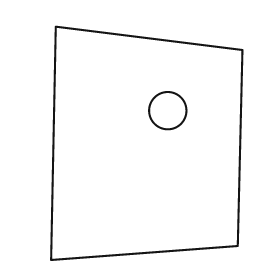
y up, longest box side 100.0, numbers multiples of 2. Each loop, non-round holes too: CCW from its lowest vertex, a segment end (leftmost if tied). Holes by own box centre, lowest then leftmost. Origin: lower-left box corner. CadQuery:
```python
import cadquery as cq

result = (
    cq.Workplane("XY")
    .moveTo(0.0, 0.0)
    .lineTo(80.0, 6.0)
    .lineTo(82.0, 90.0)
    .lineTo(2.0, 100.0)
    .close()
    .moveTo(50.0, 64.0)
    .circle(8.0)
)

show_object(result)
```